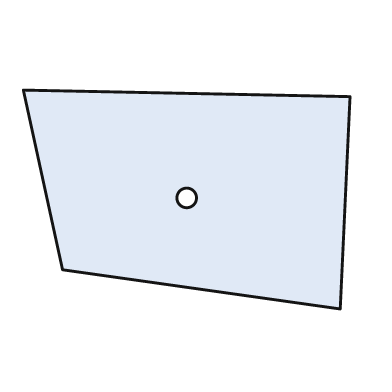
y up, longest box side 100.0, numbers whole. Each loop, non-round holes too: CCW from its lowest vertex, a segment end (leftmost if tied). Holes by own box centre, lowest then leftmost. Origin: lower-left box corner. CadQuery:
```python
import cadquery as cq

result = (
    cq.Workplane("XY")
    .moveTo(97.0, 0.0)
    .lineTo(100.0, 65.0)
    .lineTo(0.0, 67.0)
    .lineTo(12.0, 12.0)
    .close()
    .moveTo(50.0, 34.0)
    .circle(3.0)
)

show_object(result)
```